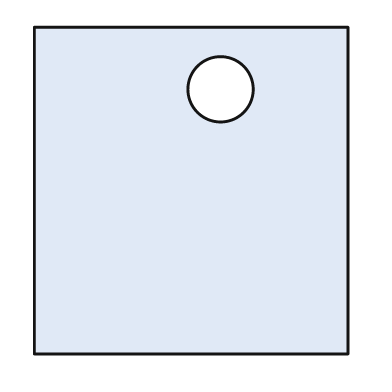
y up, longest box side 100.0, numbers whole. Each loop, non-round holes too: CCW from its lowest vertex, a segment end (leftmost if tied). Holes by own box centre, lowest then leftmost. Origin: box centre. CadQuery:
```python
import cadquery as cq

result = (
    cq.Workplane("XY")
    .moveTo(-48.0, -50.0)
    .lineTo(48.0, -50.0)
    .lineTo(48.0, 50.0)
    .lineTo(-48.0, 50.0)
    .close()
    .moveTo(9.0, 31.0)
    .circle(10.0)
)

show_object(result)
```